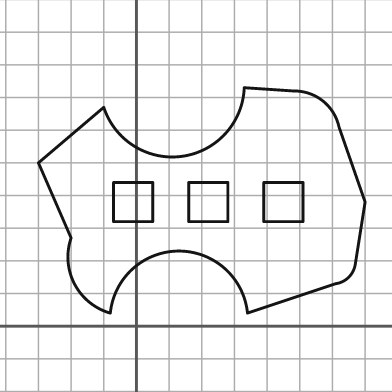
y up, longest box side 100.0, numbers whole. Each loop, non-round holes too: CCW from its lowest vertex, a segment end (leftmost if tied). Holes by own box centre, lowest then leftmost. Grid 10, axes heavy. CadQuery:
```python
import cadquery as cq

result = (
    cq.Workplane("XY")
    .moveTo(-8.0, 4.0)
    .threePointArc((13.0, 23.0), (34.0, 4.0))
    .lineTo(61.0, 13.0)
    .threePointArc((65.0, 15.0), (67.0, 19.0))
    .lineTo(70.0, 38.0)
    .lineTo(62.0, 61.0)
    .threePointArc((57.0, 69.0), (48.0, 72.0))
    .lineTo(33.0, 73.0)
    .threePointArc((14.0, 52.0), (-10.0, 67.0))
    .lineTo(-30.0, 50.0)
    .lineTo(-20.0, 27.0)
    .threePointArc((-19.0, 13.0), (-8.0, 4.0))
    .close()
    .moveTo(-7.0, 32.0)
    .lineTo(5.0, 32.0)
    .lineTo(5.0, 44.0)
    .lineTo(-7.0, 44.0)
    .close()
    .moveTo(16.0, 32.0)
    .lineTo(28.0, 32.0)
    .lineTo(28.0, 44.0)
    .lineTo(16.0, 44.0)
    .close()
    .moveTo(39.0, 32.0)
    .lineTo(51.0, 32.0)
    .lineTo(51.0, 44.0)
    .lineTo(39.0, 44.0)
    .close()
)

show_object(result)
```